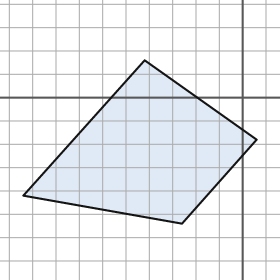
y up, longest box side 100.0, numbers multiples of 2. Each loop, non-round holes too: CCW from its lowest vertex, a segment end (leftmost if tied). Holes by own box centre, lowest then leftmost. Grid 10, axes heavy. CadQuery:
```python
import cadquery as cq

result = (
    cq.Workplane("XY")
    .moveTo(-26.0, -54.0)
    .lineTo(6.0, -18.0)
    .lineTo(-42.0, 16.0)
    .lineTo(-94.0, -42.0)
    .close()
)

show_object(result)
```